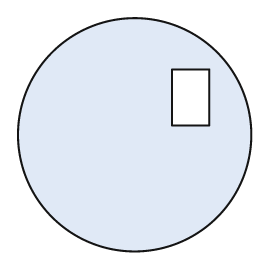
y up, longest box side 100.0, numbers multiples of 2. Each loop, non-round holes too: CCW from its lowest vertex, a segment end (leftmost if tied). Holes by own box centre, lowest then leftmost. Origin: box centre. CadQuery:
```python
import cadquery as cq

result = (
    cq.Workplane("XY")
    .moveTo(0.0, 0.0)
    .circle(50.0)
    .moveTo(16.0, 4.0)
    .lineTo(32.0, 4.0)
    .lineTo(32.0, 28.0)
    .lineTo(16.0, 28.0)
    .close()
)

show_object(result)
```